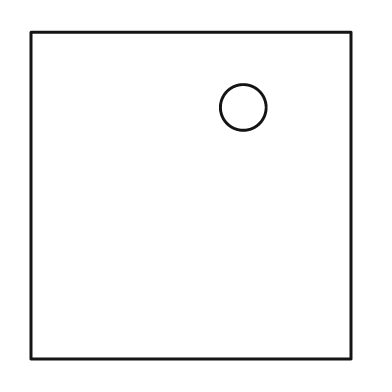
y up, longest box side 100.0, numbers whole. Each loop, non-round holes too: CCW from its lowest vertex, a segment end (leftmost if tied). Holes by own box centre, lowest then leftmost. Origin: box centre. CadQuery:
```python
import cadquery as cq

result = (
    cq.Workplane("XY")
    .moveTo(-49.0, -50.0)
    .lineTo(49.0, -50.0)
    .lineTo(49.0, 50.0)
    .lineTo(-49.0, 50.0)
    .close()
    .moveTo(16.0, 27.0)
    .circle(7.0)
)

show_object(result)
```